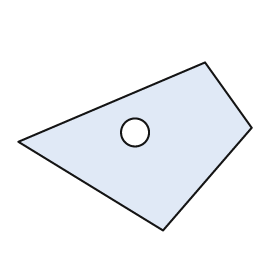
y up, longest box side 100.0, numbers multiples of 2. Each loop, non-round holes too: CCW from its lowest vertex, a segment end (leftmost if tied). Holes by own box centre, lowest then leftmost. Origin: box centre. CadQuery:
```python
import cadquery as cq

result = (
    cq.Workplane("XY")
    .moveTo(12.0, -36.0)
    .lineTo(50.0, 8.0)
    .lineTo(30.0, 36.0)
    .lineTo(-50.0, 2.0)
    .close()
    .moveTo(0.0, 6.0)
    .circle(6.0)
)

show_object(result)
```